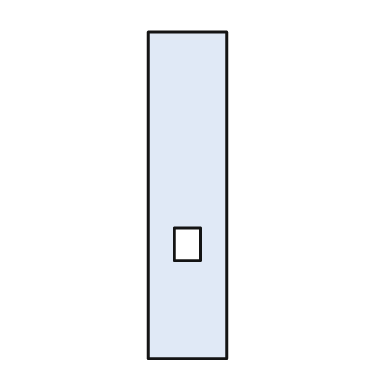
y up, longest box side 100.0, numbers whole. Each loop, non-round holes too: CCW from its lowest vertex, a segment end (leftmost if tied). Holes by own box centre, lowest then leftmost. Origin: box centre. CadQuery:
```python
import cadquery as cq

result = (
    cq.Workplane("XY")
    .moveTo(-12.0, -50.0)
    .lineTo(12.0, -50.0)
    .lineTo(12.0, 50.0)
    .lineTo(-12.0, 50.0)
    .close()
    .moveTo(-4.0, -20.0)
    .lineTo(4.0, -20.0)
    .lineTo(4.0, -10.0)
    .lineTo(-4.0, -10.0)
    .close()
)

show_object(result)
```